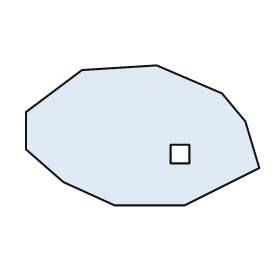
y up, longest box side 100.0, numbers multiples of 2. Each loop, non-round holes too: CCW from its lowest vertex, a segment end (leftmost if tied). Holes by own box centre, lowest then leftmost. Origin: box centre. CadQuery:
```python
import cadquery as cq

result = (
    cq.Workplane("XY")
    .moveTo(-12.0, -30.0)
    .lineTo(18.0, -30.0)
    .lineTo(50.0, -14.0)
    .lineTo(44.0, 6.0)
    .lineTo(34.0, 18.0)
    .lineTo(6.0, 30.0)
    .lineTo(-26.0, 28.0)
    .lineTo(-50.0, 10.0)
    .lineTo(-50.0, -6.0)
    .lineTo(-34.0, -20.0)
    .close()
    .moveTo(12.0, -12.0)
    .lineTo(20.0, -12.0)
    .lineTo(20.0, -4.0)
    .lineTo(12.0, -4.0)
    .close()
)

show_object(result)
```